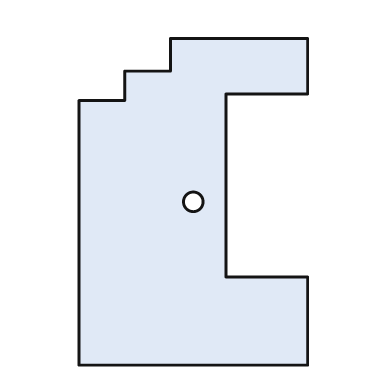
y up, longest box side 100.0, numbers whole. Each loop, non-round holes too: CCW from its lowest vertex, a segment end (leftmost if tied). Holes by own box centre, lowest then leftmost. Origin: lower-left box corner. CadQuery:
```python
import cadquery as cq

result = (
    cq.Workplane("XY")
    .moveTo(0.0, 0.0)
    .lineTo(70.0, 0.0)
    .lineTo(70.0, 27.0)
    .lineTo(45.0, 27.0)
    .lineTo(45.0, 83.0)
    .lineTo(70.0, 83.0)
    .lineTo(70.0, 100.0)
    .lineTo(28.0, 100.0)
    .lineTo(28.0, 90.0)
    .lineTo(14.0, 90.0)
    .lineTo(14.0, 81.0)
    .lineTo(0.0, 81.0)
    .close()
    .moveTo(35.0, 50.0)
    .circle(3.0)
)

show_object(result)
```